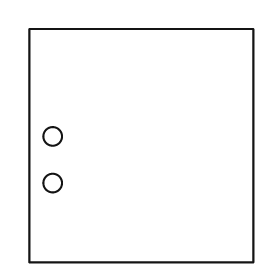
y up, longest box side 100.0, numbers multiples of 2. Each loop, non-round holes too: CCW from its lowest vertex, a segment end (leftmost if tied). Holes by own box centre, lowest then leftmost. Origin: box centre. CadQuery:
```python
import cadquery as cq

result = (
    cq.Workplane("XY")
    .moveTo(-48.0, -50.0)
    .lineTo(48.0, -50.0)
    .lineTo(48.0, 50.0)
    .lineTo(-48.0, 50.0)
    .close()
    .moveTo(-38.0, -16.0)
    .circle(4.0)
    .moveTo(-38.0, 4.0)
    .circle(4.0)
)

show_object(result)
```